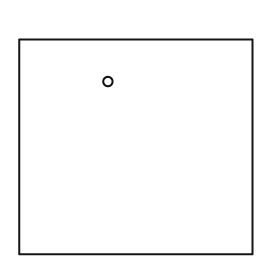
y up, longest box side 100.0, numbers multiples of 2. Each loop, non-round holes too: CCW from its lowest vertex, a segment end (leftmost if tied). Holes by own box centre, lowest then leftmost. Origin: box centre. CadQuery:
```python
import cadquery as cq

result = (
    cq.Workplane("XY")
    .moveTo(-50.0, -46.0)
    .lineTo(50.0, -46.0)
    .lineTo(50.0, 46.0)
    .lineTo(-50.0, 46.0)
    .close()
    .moveTo(-12.0, 28.0)
    .circle(2.0)
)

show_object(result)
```